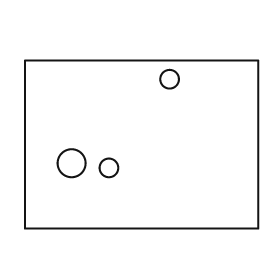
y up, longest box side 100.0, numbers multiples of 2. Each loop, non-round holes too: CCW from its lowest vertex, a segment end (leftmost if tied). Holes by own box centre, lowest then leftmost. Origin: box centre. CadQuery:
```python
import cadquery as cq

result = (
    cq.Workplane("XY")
    .moveTo(-50.0, -36.0)
    .lineTo(50.0, -36.0)
    .lineTo(50.0, 36.0)
    .lineTo(-50.0, 36.0)
    .close()
    .moveTo(-14.0, -10.0)
    .circle(4.0)
    .moveTo(-30.0, -8.0)
    .circle(6.0)
    .moveTo(12.0, 28.0)
    .circle(4.0)
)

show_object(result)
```